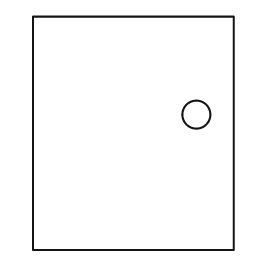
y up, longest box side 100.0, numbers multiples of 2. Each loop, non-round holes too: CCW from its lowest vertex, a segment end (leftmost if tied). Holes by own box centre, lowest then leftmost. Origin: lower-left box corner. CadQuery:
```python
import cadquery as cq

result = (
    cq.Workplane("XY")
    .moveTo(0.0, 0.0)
    .lineTo(86.0, 0.0)
    .lineTo(86.0, 100.0)
    .lineTo(0.0, 100.0)
    .close()
    .moveTo(70.0, 58.0)
    .circle(6.0)
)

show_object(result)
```